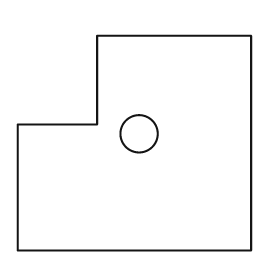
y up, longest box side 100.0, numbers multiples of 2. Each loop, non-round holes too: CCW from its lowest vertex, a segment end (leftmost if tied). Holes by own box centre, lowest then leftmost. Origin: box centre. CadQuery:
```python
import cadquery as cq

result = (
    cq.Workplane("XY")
    .moveTo(-50.0, -46.0)
    .lineTo(50.0, -46.0)
    .lineTo(50.0, 46.0)
    .lineTo(-16.0, 46.0)
    .lineTo(-16.0, 8.0)
    .lineTo(-50.0, 8.0)
    .close()
    .moveTo(2.0, 4.0)
    .circle(8.0)
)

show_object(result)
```